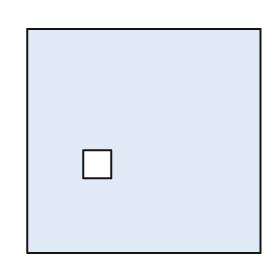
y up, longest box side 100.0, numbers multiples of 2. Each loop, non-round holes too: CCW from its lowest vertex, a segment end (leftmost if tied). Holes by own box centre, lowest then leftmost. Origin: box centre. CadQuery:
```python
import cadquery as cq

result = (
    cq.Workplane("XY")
    .moveTo(-50.0, -48.0)
    .lineTo(50.0, -48.0)
    .lineTo(50.0, 48.0)
    .lineTo(-50.0, 48.0)
    .close()
    .moveTo(-26.0, -16.0)
    .lineTo(-14.0, -16.0)
    .lineTo(-14.0, -4.0)
    .lineTo(-26.0, -4.0)
    .close()
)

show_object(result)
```